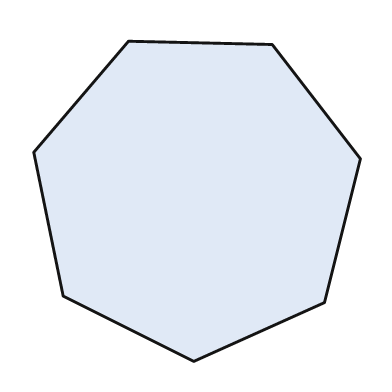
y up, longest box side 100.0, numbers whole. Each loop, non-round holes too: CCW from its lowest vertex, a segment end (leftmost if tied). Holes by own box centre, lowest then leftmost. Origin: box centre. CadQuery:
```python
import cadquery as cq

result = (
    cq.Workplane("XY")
    .moveTo(-1.0, -49.0)
    .lineTo(39.0, -31.0)
    .lineTo(50.0, 13.0)
    .lineTo(23.0, 48.0)
    .lineTo(-21.0, 49.0)
    .lineTo(-50.0, 15.0)
    .lineTo(-41.0, -29.0)
    .close()
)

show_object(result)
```